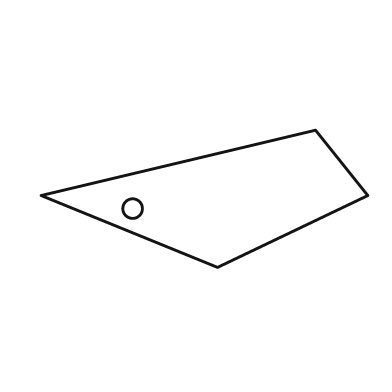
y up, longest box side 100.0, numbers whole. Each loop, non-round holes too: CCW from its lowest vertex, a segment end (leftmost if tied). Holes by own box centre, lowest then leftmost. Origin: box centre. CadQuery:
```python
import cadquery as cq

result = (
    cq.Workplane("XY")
    .moveTo(4.0, -21.0)
    .lineTo(50.0, 1.0)
    .lineTo(34.0, 21.0)
    .lineTo(-50.0, 1.0)
    .close()
    .moveTo(-22.0, -3.0)
    .circle(3.0)
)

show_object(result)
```